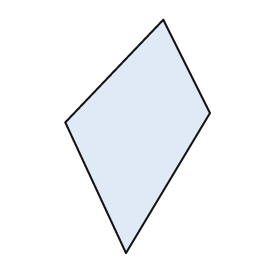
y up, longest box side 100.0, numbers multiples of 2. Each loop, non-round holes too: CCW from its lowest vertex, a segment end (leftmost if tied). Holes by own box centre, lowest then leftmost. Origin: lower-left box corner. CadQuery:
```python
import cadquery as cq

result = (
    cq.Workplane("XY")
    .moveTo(26.0, 0.0)
    .lineTo(62.0, 60.0)
    .lineTo(42.0, 100.0)
    .lineTo(0.0, 56.0)
    .close()
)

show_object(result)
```